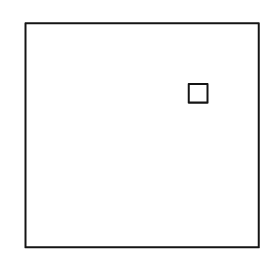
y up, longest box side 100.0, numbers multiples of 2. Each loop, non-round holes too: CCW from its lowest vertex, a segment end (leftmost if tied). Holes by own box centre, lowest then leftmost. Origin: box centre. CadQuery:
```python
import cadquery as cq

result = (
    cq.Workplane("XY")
    .moveTo(-50.0, -48.0)
    .lineTo(50.0, -48.0)
    .lineTo(50.0, 48.0)
    .lineTo(-50.0, 48.0)
    .close()
    .moveTo(20.0, 14.0)
    .lineTo(28.0, 14.0)
    .lineTo(28.0, 22.0)
    .lineTo(20.0, 22.0)
    .close()
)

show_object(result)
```